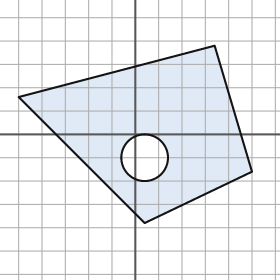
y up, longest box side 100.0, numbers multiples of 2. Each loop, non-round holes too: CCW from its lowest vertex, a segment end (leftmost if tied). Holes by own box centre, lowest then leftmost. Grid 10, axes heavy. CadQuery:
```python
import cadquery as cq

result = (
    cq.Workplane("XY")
    .moveTo(4.0, -38.0)
    .lineTo(50.0, -16.0)
    .lineTo(34.0, 38.0)
    .lineTo(-50.0, 16.0)
    .close()
    .moveTo(4.0, -10.0)
    .circle(10.0)
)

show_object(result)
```